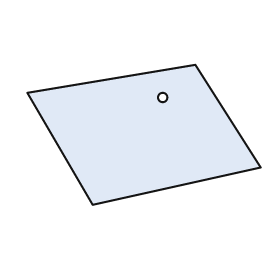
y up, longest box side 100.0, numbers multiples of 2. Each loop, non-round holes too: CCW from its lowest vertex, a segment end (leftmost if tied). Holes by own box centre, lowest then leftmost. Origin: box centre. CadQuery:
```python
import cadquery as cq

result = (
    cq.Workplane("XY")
    .moveTo(-22.0, -30.0)
    .lineTo(50.0, -14.0)
    .lineTo(22.0, 30.0)
    .lineTo(-50.0, 18.0)
    .close()
    .moveTo(8.0, 16.0)
    .circle(2.0)
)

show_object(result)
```